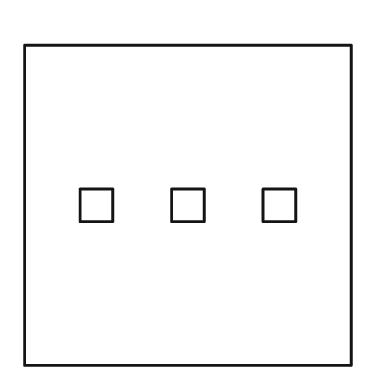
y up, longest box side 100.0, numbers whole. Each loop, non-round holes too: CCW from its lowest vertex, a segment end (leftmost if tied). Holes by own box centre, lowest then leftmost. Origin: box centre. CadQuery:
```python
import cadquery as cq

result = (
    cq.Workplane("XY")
    .moveTo(-50.0, -49.0)
    .lineTo(50.0, -49.0)
    .lineTo(50.0, 49.0)
    .lineTo(-50.0, 49.0)
    .close()
    .moveTo(-33.0, -5.0)
    .lineTo(-23.0, -5.0)
    .lineTo(-23.0, 5.0)
    .lineTo(-33.0, 5.0)
    .close()
    .moveTo(-5.0, -5.0)
    .lineTo(5.0, -5.0)
    .lineTo(5.0, 5.0)
    .lineTo(-5.0, 5.0)
    .close()
    .moveTo(23.0, -5.0)
    .lineTo(33.0, -5.0)
    .lineTo(33.0, 5.0)
    .lineTo(23.0, 5.0)
    .close()
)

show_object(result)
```